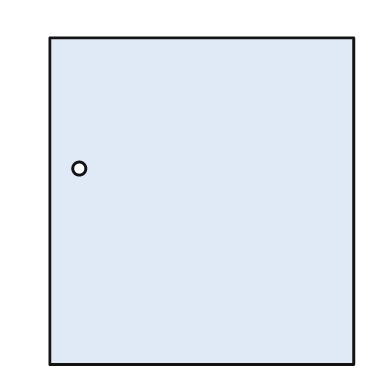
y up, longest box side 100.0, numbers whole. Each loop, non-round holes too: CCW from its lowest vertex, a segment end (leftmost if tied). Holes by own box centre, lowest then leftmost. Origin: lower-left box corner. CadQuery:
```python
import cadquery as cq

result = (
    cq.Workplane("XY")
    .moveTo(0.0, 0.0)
    .lineTo(93.0, 0.0)
    .lineTo(93.0, 100.0)
    .lineTo(0.0, 100.0)
    .close()
    .moveTo(9.0, 60.0)
    .circle(2.0)
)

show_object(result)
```